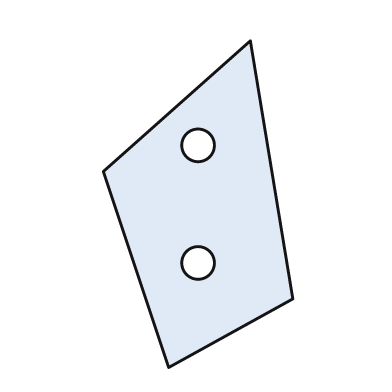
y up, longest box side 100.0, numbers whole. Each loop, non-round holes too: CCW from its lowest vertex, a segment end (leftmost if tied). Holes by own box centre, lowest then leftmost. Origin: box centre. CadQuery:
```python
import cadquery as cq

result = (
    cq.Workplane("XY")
    .moveTo(-9.0, -50.0)
    .lineTo(29.0, -29.0)
    .lineTo(16.0, 50.0)
    .lineTo(-29.0, 10.0)
    .close()
    .moveTo(0.0, -18.0)
    .circle(5.0)
    .moveTo(0.0, 18.0)
    .circle(5.0)
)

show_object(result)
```